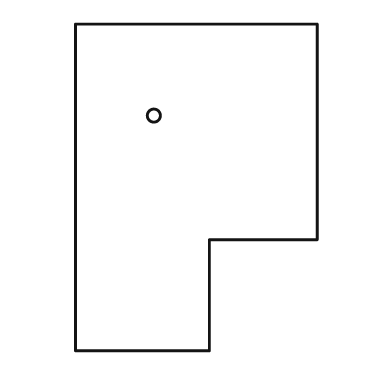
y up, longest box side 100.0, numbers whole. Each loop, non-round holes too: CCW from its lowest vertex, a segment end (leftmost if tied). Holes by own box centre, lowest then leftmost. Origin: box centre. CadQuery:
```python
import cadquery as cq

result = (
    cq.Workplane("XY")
    .moveTo(-37.0, -50.0)
    .lineTo(4.0, -50.0)
    .lineTo(4.0, -16.0)
    .lineTo(37.0, -16.0)
    .lineTo(37.0, 50.0)
    .lineTo(-37.0, 50.0)
    .close()
    .moveTo(-13.0, 22.0)
    .circle(2.0)
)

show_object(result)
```